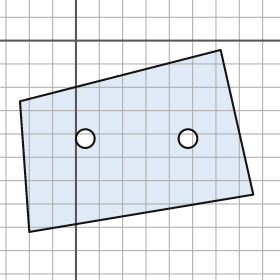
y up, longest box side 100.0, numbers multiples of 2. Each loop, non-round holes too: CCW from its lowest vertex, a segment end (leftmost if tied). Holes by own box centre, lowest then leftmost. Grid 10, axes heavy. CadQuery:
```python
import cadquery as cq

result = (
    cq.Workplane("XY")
    .moveTo(-20.0, -82.0)
    .lineTo(76.0, -66.0)
    .lineTo(62.0, -4.0)
    .lineTo(-24.0, -26.0)
    .close()
    .moveTo(4.0, -42.0)
    .circle(4.0)
    .moveTo(48.0, -42.0)
    .circle(4.0)
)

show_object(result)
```